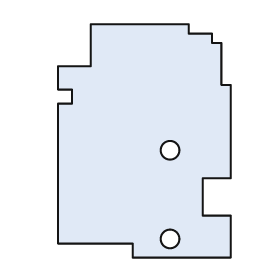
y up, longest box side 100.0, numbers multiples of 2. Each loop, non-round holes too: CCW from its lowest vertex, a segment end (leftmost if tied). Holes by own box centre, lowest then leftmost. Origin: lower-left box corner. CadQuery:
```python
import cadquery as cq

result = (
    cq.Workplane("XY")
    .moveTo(32.0, 0.0)
    .lineTo(74.0, 0.0)
    .lineTo(74.0, 18.0)
    .lineTo(62.0, 18.0)
    .lineTo(62.0, 34.0)
    .lineTo(74.0, 34.0)
    .lineTo(74.0, 74.0)
    .lineTo(70.0, 74.0)
    .lineTo(70.0, 92.0)
    .lineTo(66.0, 92.0)
    .lineTo(66.0, 96.0)
    .lineTo(56.0, 96.0)
    .lineTo(56.0, 100.0)
    .lineTo(14.0, 100.0)
    .lineTo(14.0, 82.0)
    .lineTo(0.0, 82.0)
    .lineTo(0.0, 72.0)
    .lineTo(6.0, 72.0)
    .lineTo(6.0, 66.0)
    .lineTo(0.0, 66.0)
    .lineTo(0.0, 6.0)
    .lineTo(32.0, 6.0)
    .close()
    .moveTo(48.0, 8.0)
    .circle(4.0)
    .moveTo(48.0, 46.0)
    .circle(4.0)
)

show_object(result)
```